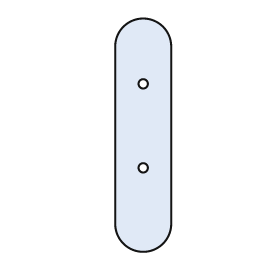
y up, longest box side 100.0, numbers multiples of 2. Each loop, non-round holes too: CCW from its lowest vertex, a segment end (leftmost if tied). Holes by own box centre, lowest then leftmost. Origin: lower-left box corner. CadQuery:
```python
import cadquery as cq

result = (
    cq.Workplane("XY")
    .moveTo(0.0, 12.0)
    .threePointArc((12.0, 0.0), (24.0, 12.0))
    .lineTo(24.0, 88.0)
    .threePointArc((12.0, 100.0), (0.0, 88.0))
    .close()
    .moveTo(12.0, 36.0)
    .circle(2.0)
    .moveTo(12.0, 72.0)
    .circle(2.0)
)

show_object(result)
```